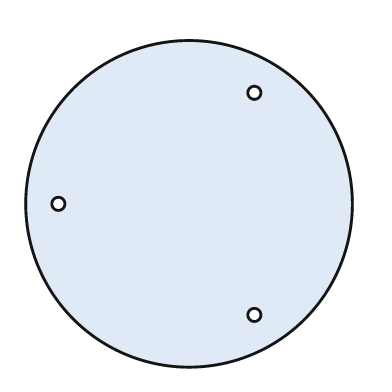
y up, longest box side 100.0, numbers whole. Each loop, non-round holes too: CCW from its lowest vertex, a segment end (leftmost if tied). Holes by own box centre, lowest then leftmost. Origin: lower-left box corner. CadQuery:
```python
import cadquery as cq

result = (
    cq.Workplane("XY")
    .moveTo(50.0, 50.0)
    .circle(50.0)
    .moveTo(70.0, 16.0)
    .circle(2.0)
    .moveTo(10.0, 50.0)
    .circle(2.0)
    .moveTo(70.0, 84.0)
    .circle(2.0)
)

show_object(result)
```